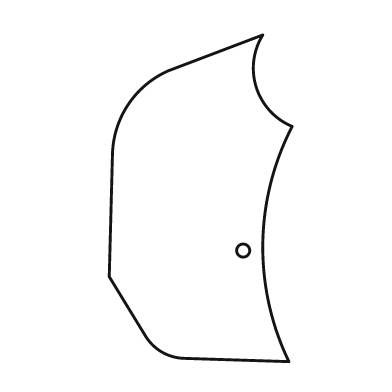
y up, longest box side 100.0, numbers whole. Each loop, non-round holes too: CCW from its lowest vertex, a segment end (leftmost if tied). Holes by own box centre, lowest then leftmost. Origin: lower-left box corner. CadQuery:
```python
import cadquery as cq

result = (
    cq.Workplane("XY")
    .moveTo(55.0, 0.0)
    .threePointArc((47.0, 36.0), (56.0, 72.0))
    .threePointArc((45.0, 84.0), (47.0, 100.0))
    .lineTo(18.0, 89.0)
    .threePointArc((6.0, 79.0), (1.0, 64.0))
    .lineTo(0.0, 26.0)
    .lineTo(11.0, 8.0)
    .threePointArc((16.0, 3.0), (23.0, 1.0))
    .close()
    .moveTo(41.0, 34.0)
    .circle(2.0)
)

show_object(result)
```